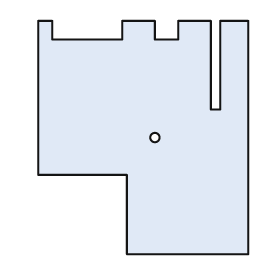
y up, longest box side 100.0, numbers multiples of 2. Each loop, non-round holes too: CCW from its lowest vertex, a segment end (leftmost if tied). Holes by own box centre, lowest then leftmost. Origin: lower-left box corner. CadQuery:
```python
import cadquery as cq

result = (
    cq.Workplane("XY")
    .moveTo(38.0, 0.0)
    .lineTo(90.0, 0.0)
    .lineTo(90.0, 100.0)
    .lineTo(78.0, 100.0)
    .lineTo(78.0, 62.0)
    .lineTo(74.0, 62.0)
    .lineTo(74.0, 100.0)
    .lineTo(60.0, 100.0)
    .lineTo(60.0, 92.0)
    .lineTo(50.0, 92.0)
    .lineTo(50.0, 100.0)
    .lineTo(36.0, 100.0)
    .lineTo(36.0, 92.0)
    .lineTo(6.0, 92.0)
    .lineTo(6.0, 100.0)
    .lineTo(0.0, 100.0)
    .lineTo(0.0, 34.0)
    .lineTo(38.0, 34.0)
    .close()
    .moveTo(50.0, 50.0)
    .circle(2.0)
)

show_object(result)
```